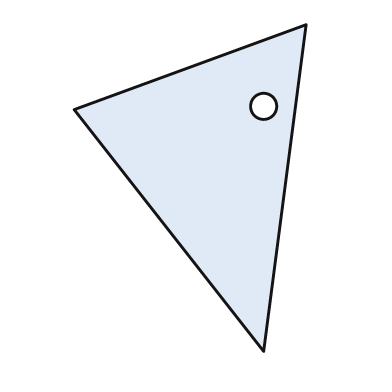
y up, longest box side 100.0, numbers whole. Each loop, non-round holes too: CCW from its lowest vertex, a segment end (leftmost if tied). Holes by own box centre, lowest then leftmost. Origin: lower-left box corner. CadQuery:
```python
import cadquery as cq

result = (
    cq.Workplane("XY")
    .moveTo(58.0, 0.0)
    .lineTo(71.0, 100.0)
    .lineTo(0.0, 74.0)
    .close()
    .moveTo(58.0, 75.0)
    .circle(4.0)
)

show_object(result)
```